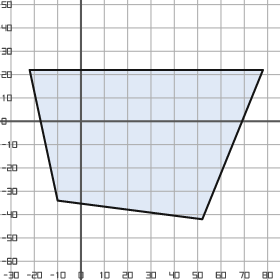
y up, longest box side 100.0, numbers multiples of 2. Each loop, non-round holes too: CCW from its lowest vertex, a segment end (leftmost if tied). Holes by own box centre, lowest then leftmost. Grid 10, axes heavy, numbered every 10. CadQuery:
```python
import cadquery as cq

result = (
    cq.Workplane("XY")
    .moveTo(52.0, -42.0)
    .lineTo(78.0, 22.0)
    .lineTo(-22.0, 22.0)
    .lineTo(-10.0, -34.0)
    .close()
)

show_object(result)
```